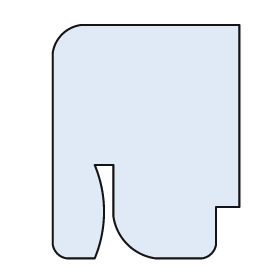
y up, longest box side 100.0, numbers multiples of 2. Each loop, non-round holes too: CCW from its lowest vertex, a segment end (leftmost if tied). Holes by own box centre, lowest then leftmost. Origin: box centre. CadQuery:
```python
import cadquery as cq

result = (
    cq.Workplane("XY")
    .moveTo(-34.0, -50.0)
    .lineTo(-22.0, -50.0)
    .threePointArc((-18.0, -30.0), (-22.0, -10.0))
    .lineTo(-14.0, -10.0)
    .lineTo(-14.0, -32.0)
    .threePointArc((-8.0, -44.0), (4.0, -50.0))
    .lineTo(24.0, -50.0)
    .threePointArc((28.0, -48.0), (30.0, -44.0))
    .lineTo(30.0, -28.0)
    .lineTo(40.0, -28.0)
    .lineTo(40.0, 50.0)
    .lineTo(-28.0, 50.0)
    .threePointArc((-36.0, 46.0), (-40.0, 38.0))
    .lineTo(-40.0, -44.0)
    .threePointArc((-38.0, -48.0), (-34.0, -50.0))
    .close()
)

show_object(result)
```